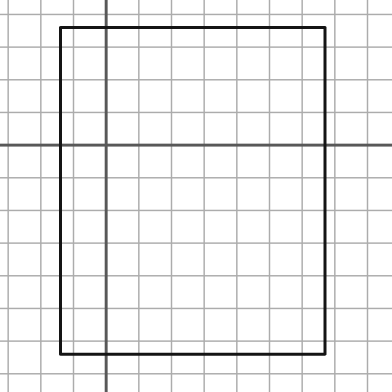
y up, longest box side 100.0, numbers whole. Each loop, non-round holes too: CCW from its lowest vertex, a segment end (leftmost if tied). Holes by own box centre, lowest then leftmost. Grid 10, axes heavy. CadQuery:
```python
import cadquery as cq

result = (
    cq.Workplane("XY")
    .moveTo(-14.0, -64.0)
    .lineTo(67.0, -64.0)
    .lineTo(67.0, 36.0)
    .lineTo(-14.0, 36.0)
    .close()
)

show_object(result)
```